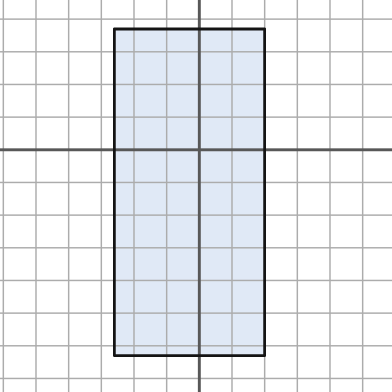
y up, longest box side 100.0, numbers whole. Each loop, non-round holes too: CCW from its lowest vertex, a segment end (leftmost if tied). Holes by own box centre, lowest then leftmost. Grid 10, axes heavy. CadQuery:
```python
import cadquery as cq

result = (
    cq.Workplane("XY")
    .moveTo(-26.0, -63.0)
    .lineTo(20.0, -63.0)
    .lineTo(20.0, 37.0)
    .lineTo(-26.0, 37.0)
    .close()
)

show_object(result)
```